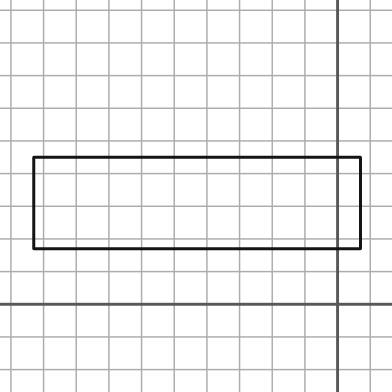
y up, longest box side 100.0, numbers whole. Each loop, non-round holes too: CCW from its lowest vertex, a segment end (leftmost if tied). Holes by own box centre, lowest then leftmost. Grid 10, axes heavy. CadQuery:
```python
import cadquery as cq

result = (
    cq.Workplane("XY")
    .moveTo(-93.0, 17.0)
    .lineTo(7.0, 17.0)
    .lineTo(7.0, 45.0)
    .lineTo(-93.0, 45.0)
    .close()
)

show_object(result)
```